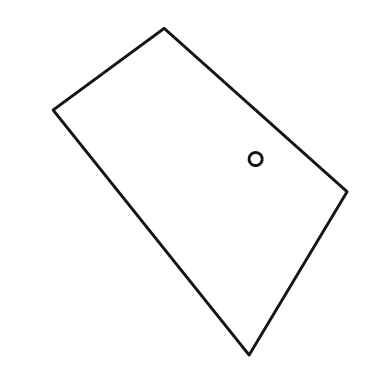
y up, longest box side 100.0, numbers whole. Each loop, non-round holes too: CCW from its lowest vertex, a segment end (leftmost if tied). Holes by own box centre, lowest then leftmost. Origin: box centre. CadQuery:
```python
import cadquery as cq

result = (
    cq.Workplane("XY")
    .moveTo(15.0, -50.0)
    .lineTo(45.0, 0.0)
    .lineTo(-11.0, 50.0)
    .lineTo(-45.0, 25.0)
    .close()
    .moveTo(17.0, 10.0)
    .circle(2.0)
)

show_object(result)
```